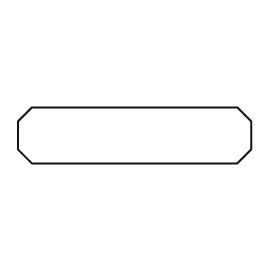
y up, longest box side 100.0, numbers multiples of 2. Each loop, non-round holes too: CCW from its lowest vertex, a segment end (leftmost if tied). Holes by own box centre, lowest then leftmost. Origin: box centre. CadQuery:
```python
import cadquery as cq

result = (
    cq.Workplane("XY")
    .moveTo(-44.0, -12.0)
    .lineTo(44.0, -12.0)
    .lineTo(50.0, -6.0)
    .lineTo(50.0, 6.0)
    .lineTo(44.0, 12.0)
    .lineTo(-44.0, 12.0)
    .lineTo(-50.0, 6.0)
    .lineTo(-50.0, -6.0)
    .close()
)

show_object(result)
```